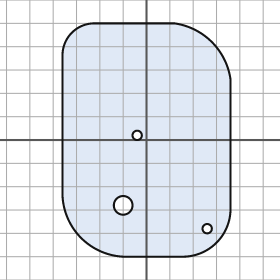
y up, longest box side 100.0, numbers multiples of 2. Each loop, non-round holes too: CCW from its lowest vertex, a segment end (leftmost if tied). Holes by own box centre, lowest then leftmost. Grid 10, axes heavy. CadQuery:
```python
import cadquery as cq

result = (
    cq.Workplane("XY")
    .moveTo(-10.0, -50.0)
    .lineTo(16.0, -50.0)
    .threePointArc((30.0, -44.0), (36.0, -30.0))
    .lineTo(36.0, 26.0)
    .threePointArc((28.0, 42.0), (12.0, 50.0))
    .lineTo(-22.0, 50.0)
    .threePointArc((-32.0, 46.0), (-36.0, 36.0))
    .lineTo(-36.0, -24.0)
    .threePointArc((-28.0, -42.0), (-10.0, -50.0))
    .close()
    .moveTo(26.0, -38.0)
    .circle(2.0)
    .moveTo(-10.0, -28.0)
    .circle(4.0)
    .moveTo(-4.0, 2.0)
    .circle(2.0)
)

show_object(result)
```